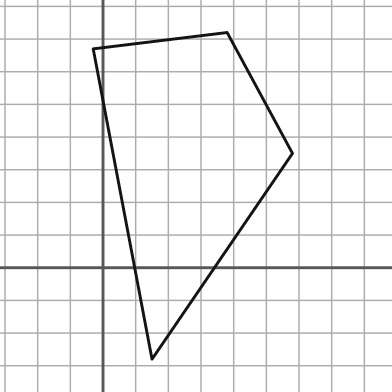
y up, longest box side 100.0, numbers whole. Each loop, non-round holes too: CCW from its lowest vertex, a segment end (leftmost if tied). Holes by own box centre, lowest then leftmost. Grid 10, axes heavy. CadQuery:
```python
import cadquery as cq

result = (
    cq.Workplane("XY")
    .moveTo(15.0, -28.0)
    .lineTo(58.0, 35.0)
    .lineTo(38.0, 72.0)
    .lineTo(-3.0, 67.0)
    .close()
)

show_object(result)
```